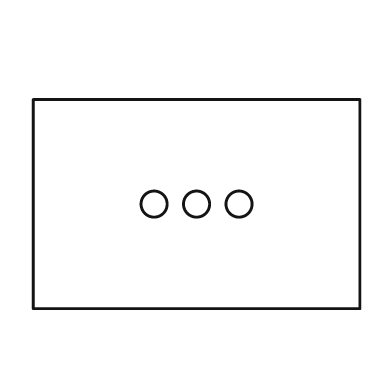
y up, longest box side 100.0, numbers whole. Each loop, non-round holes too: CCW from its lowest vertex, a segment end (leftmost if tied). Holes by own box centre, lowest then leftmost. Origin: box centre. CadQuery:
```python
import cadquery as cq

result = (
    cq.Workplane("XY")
    .moveTo(-50.0, -32.0)
    .lineTo(50.0, -32.0)
    .lineTo(50.0, 32.0)
    .lineTo(-50.0, 32.0)
    .close()
    .moveTo(-13.0, 0.0)
    .circle(4.0)
    .moveTo(0.0, 0.0)
    .circle(4.0)
    .moveTo(13.0, 0.0)
    .circle(4.0)
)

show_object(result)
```